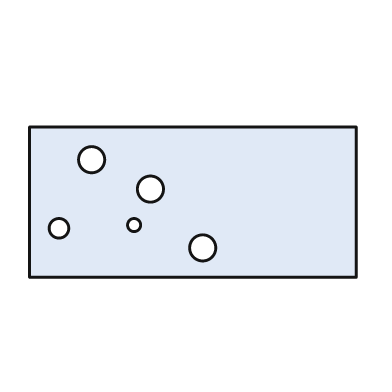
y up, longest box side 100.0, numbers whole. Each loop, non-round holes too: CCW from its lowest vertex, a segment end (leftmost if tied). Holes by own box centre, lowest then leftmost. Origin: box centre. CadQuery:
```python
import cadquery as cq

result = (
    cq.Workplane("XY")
    .moveTo(-50.0, -23.0)
    .lineTo(50.0, -23.0)
    .lineTo(50.0, 23.0)
    .lineTo(-50.0, 23.0)
    .close()
    .moveTo(3.0, -14.0)
    .circle(4.0)
    .moveTo(-41.0, -8.0)
    .circle(3.0)
    .moveTo(-18.0, -7.0)
    .circle(2.0)
    .moveTo(-13.0, 4.0)
    .circle(4.0)
    .moveTo(-31.0, 13.0)
    .circle(4.0)
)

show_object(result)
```